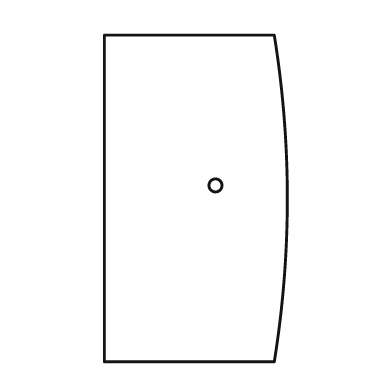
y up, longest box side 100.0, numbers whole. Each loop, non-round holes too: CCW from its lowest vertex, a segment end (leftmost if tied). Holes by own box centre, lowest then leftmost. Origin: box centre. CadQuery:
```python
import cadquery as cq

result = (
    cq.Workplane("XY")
    .moveTo(-28.0, -50.0)
    .lineTo(24.0, -50.0)
    .threePointArc((28.0, 0.0), (24.0, 50.0))
    .lineTo(-28.0, 50.0)
    .close()
    .moveTo(6.0, 4.0)
    .circle(2.0)
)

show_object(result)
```